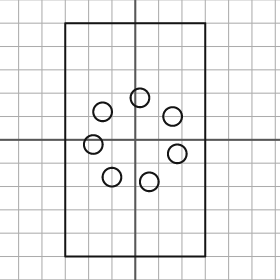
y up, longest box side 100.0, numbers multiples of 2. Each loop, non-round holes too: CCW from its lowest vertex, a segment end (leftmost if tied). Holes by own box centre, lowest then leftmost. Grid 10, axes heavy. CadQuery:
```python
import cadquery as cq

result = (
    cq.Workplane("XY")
    .moveTo(-30.0, -50.0)
    .lineTo(30.0, -50.0)
    .lineTo(30.0, 50.0)
    .lineTo(-30.0, 50.0)
    .close()
    .moveTo(6.0, -18.0)
    .circle(4.0)
    .moveTo(-10.0, -16.0)
    .circle(4.0)
    .moveTo(18.0, -6.0)
    .circle(4.0)
    .moveTo(-18.0, -2.0)
    .circle(4.0)
    .moveTo(16.0, 10.0)
    .circle(4.0)
    .moveTo(-14.0, 12.0)
    .circle(4.0)
    .moveTo(2.0, 18.0)
    .circle(4.0)
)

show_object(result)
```